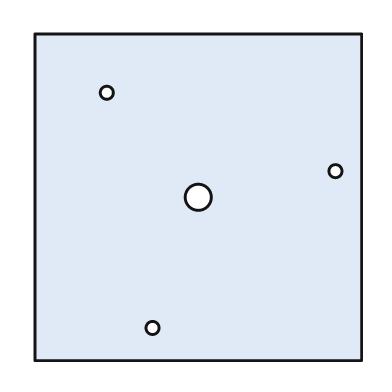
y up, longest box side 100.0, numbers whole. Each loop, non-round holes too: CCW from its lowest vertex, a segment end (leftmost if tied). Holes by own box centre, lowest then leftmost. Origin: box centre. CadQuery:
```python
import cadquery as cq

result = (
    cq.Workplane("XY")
    .moveTo(-50.0, -50.0)
    .lineTo(50.0, -50.0)
    .lineTo(50.0, 50.0)
    .lineTo(-50.0, 50.0)
    .close()
    .moveTo(-14.0, -40.0)
    .circle(2.0)
    .moveTo(0.0, 0.0)
    .circle(4.0)
    .moveTo(42.0, 8.0)
    .circle(2.0)
    .moveTo(-28.0, 32.0)
    .circle(2.0)
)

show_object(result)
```